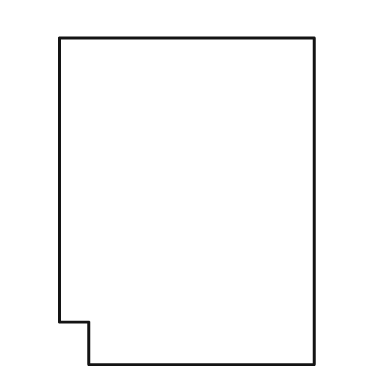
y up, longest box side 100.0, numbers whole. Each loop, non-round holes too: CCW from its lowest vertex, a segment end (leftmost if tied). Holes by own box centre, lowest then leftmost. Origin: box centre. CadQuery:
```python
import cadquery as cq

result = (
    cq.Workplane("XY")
    .moveTo(-30.0, -50.0)
    .lineTo(39.0, -50.0)
    .lineTo(39.0, 50.0)
    .lineTo(-39.0, 50.0)
    .lineTo(-39.0, -37.0)
    .lineTo(-30.0, -37.0)
    .close()
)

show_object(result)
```